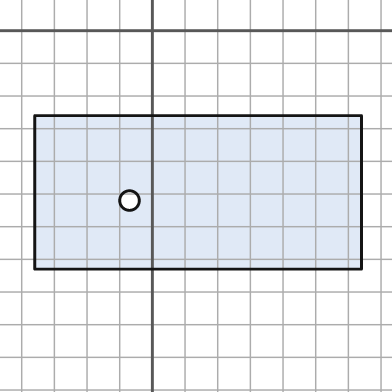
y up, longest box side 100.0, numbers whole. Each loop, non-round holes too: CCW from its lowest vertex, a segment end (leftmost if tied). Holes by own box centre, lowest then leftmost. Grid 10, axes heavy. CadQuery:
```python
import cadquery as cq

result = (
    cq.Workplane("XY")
    .moveTo(-36.0, -73.0)
    .lineTo(64.0, -73.0)
    .lineTo(64.0, -26.0)
    .lineTo(-36.0, -26.0)
    .close()
    .moveTo(-7.0, -52.0)
    .circle(3.0)
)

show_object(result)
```